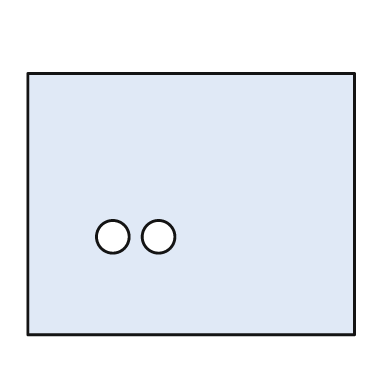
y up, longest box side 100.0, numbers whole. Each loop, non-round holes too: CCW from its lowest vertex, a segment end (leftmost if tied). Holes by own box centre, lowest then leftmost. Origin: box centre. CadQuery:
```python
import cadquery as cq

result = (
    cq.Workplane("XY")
    .moveTo(-50.0, -40.0)
    .lineTo(50.0, -40.0)
    .lineTo(50.0, 40.0)
    .lineTo(-50.0, 40.0)
    .close()
    .moveTo(-24.0, -10.0)
    .circle(5.0)
    .moveTo(-10.0, -10.0)
    .circle(5.0)
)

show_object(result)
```